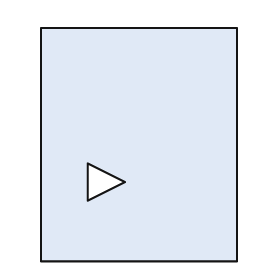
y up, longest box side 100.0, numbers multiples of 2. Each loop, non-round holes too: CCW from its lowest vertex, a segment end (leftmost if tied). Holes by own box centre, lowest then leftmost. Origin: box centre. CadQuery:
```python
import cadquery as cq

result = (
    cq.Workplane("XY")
    .moveTo(-42.0, -50.0)
    .lineTo(42.0, -50.0)
    .lineTo(42.0, 50.0)
    .lineTo(-42.0, 50.0)
    .close()
    .moveTo(-22.0, -24.0)
    .lineTo(-6.0, -16.0)
    .lineTo(-22.0, -8.0)
    .close()
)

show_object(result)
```